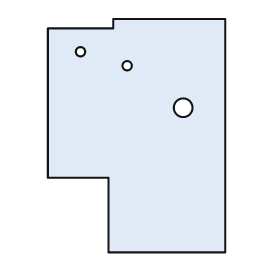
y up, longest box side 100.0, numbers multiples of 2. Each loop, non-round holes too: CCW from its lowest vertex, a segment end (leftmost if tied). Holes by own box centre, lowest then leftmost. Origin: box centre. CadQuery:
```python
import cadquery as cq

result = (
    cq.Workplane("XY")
    .moveTo(-12.0, -50.0)
    .lineTo(38.0, -50.0)
    .lineTo(38.0, 50.0)
    .lineTo(-10.0, 50.0)
    .lineTo(-10.0, 46.0)
    .lineTo(-38.0, 46.0)
    .lineTo(-38.0, -18.0)
    .lineTo(-12.0, -18.0)
    .close()
    .moveTo(20.0, 12.0)
    .circle(4.0)
    .moveTo(-4.0, 30.0)
    .circle(2.0)
    .moveTo(-24.0, 36.0)
    .circle(2.0)
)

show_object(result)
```